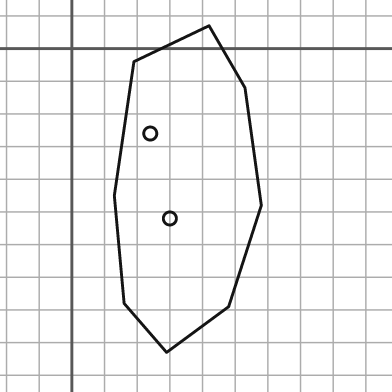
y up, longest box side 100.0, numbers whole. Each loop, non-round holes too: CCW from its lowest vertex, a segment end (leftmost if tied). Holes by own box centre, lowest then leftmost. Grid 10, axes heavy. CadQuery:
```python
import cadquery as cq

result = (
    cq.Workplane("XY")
    .moveTo(29.0, -93.0)
    .lineTo(48.0, -79.0)
    .lineTo(58.0, -48.0)
    .lineTo(53.0, -12.0)
    .lineTo(42.0, 7.0)
    .lineTo(19.0, -4.0)
    .lineTo(13.0, -45.0)
    .lineTo(16.0, -78.0)
    .close()
    .moveTo(30.0, -52.0)
    .circle(2.0)
    .moveTo(24.0, -26.0)
    .circle(2.0)
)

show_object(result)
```